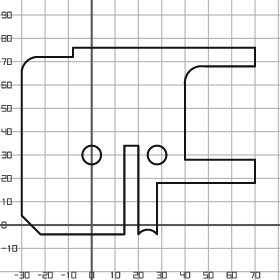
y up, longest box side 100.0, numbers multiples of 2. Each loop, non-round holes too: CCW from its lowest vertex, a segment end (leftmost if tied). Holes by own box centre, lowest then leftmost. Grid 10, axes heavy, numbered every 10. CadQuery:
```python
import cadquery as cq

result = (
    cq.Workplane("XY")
    .moveTo(-22.0, -4.0)
    .lineTo(14.0, -4.0)
    .lineTo(14.0, 34.0)
    .lineTo(20.0, 34.0)
    .lineTo(20.0, -4.0)
    .threePointArc((24.0, -2.0), (28.0, -4.0))
    .lineTo(28.0, 18.0)
    .lineTo(70.0, 18.0)
    .lineTo(70.0, 28.0)
    .lineTo(40.0, 28.0)
    .lineTo(40.0, 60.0)
    .threePointArc((42.0, 66.0), (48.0, 68.0))
    .lineTo(70.0, 68.0)
    .lineTo(70.0, 76.0)
    .lineTo(-8.0, 76.0)
    .lineTo(-8.0, 72.0)
    .lineTo(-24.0, 72.0)
    .threePointArc((-28.0, 70.0), (-30.0, 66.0))
    .lineTo(-30.0, 4.0)
    .close()
    .moveTo(0.0, 30.0)
    .circle(4.0)
    .moveTo(28.0, 30.0)
    .circle(4.0)
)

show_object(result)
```